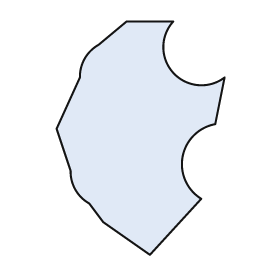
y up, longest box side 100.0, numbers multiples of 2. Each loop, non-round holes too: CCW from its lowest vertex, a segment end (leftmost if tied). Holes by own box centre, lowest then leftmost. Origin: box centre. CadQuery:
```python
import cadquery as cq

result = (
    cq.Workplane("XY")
    .moveTo(4.0, -50.0)
    .lineTo(26.0, -26.0)
    .threePointArc((18.0, -8.0), (32.0, 6.0))
    .lineTo(36.0, 26.0)
    .threePointArc((14.0, 28.0), (14.0, 50.0))
    .lineTo(-6.0, 50.0)
    .lineTo(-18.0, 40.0)
    .threePointArc((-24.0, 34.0), (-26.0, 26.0))
    .lineTo(-36.0, 4.0)
    .lineTo(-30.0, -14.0)
    .threePointArc((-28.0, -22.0), (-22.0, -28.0))
    .lineTo(-16.0, -36.0)
    .close()
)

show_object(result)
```